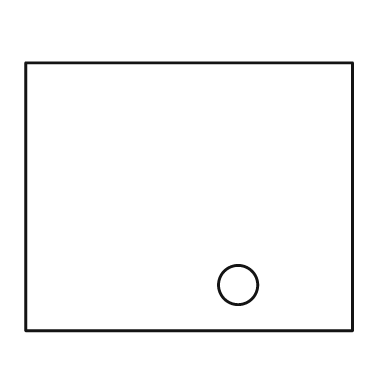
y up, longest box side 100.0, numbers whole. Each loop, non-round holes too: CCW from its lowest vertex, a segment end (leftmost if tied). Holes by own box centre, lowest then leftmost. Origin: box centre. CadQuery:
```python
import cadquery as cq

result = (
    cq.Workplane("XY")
    .moveTo(-50.0, -41.0)
    .lineTo(50.0, -41.0)
    .lineTo(50.0, 41.0)
    .lineTo(-50.0, 41.0)
    .close()
    .moveTo(15.0, -27.0)
    .circle(6.0)
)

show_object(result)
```